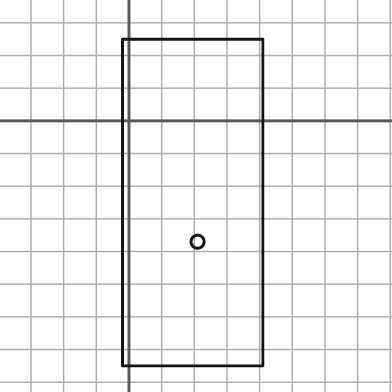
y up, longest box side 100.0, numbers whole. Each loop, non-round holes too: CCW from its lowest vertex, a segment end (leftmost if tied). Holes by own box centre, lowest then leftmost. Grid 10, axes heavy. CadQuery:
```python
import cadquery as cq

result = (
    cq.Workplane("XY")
    .moveTo(-2.0, -75.0)
    .lineTo(41.0, -75.0)
    .lineTo(41.0, 25.0)
    .lineTo(-2.0, 25.0)
    .close()
    .moveTo(21.0, -37.0)
    .circle(2.0)
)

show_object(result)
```